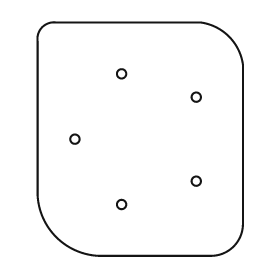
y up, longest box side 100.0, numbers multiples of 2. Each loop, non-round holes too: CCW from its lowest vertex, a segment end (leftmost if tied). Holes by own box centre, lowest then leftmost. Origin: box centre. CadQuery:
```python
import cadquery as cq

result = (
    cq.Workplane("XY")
    .moveTo(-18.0, -50.0)
    .lineTo(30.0, -50.0)
    .threePointArc((40.0, -46.0), (44.0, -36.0))
    .lineTo(44.0, 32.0)
    .threePointArc((38.0, 44.0), (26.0, 50.0))
    .lineTo(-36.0, 50.0)
    .threePointArc((-42.0, 48.0), (-44.0, 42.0))
    .lineTo(-44.0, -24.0)
    .threePointArc((-36.0, -42.0), (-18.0, -50.0))
    .close()
    .moveTo(-8.0, -28.0)
    .circle(2.0)
    .moveTo(24.0, -18.0)
    .circle(2.0)
    .moveTo(-28.0, 0.0)
    .circle(2.0)
    .moveTo(24.0, 18.0)
    .circle(2.0)
    .moveTo(-8.0, 28.0)
    .circle(2.0)
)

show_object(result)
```